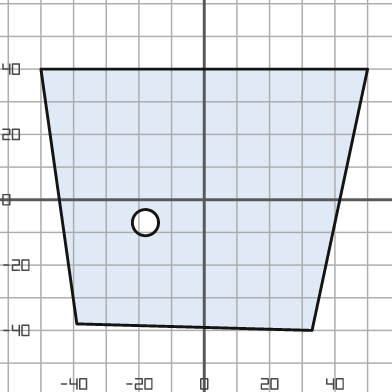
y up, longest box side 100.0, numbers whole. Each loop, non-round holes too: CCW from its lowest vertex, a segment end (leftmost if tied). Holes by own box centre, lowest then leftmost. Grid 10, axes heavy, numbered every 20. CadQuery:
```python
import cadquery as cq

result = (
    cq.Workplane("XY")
    .moveTo(33.0, -40.0)
    .lineTo(50.0, 40.0)
    .lineTo(-50.0, 40.0)
    .lineTo(-39.0, -38.0)
    .close()
    .moveTo(-18.0, -7.0)
    .circle(4.0)
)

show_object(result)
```